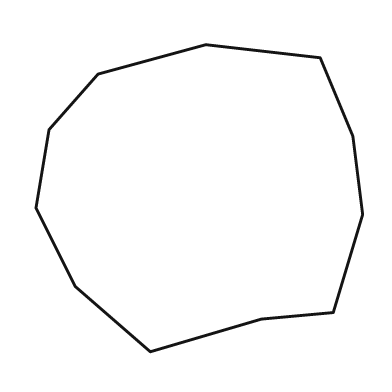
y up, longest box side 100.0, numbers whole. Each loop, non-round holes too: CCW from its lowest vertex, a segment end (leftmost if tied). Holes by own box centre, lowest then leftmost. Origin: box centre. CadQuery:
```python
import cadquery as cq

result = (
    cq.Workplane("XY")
    .moveTo(-15.0, -47.0)
    .lineTo(19.0, -37.0)
    .lineTo(41.0, -35.0)
    .lineTo(50.0, -5.0)
    .lineTo(47.0, 19.0)
    .lineTo(37.0, 43.0)
    .lineTo(2.0, 47.0)
    .lineTo(-31.0, 38.0)
    .lineTo(-46.0, 21.0)
    .lineTo(-50.0, -3.0)
    .lineTo(-38.0, -27.0)
    .close()
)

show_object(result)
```